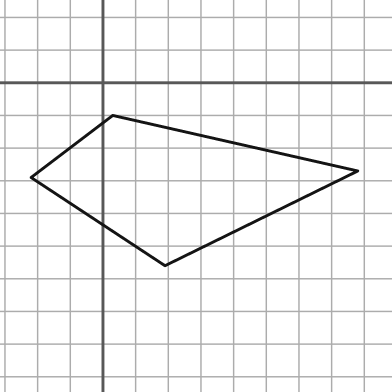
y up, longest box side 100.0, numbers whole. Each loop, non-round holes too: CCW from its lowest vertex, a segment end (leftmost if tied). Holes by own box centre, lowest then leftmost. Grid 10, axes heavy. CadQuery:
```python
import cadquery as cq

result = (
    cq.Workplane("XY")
    .moveTo(19.0, -56.0)
    .lineTo(78.0, -27.0)
    .lineTo(3.0, -10.0)
    .lineTo(-22.0, -29.0)
    .close()
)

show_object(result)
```